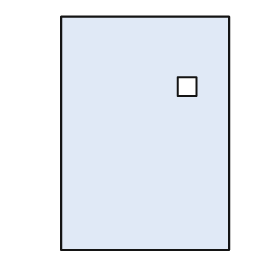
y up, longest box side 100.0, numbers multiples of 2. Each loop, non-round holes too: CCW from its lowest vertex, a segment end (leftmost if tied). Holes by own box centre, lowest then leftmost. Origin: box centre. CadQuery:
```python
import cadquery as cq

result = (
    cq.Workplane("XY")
    .moveTo(-36.0, -50.0)
    .lineTo(36.0, -50.0)
    .lineTo(36.0, 50.0)
    .lineTo(-36.0, 50.0)
    .close()
    .moveTo(14.0, 16.0)
    .lineTo(22.0, 16.0)
    .lineTo(22.0, 24.0)
    .lineTo(14.0, 24.0)
    .close()
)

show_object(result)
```